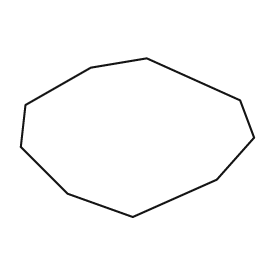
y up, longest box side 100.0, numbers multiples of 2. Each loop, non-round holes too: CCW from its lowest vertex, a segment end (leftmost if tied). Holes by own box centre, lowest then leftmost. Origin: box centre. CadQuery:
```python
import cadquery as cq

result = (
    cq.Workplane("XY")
    .moveTo(-2.0, -34.0)
    .lineTo(34.0, -18.0)
    .lineTo(50.0, 0.0)
    .lineTo(44.0, 16.0)
    .lineTo(4.0, 34.0)
    .lineTo(-20.0, 30.0)
    .lineTo(-48.0, 14.0)
    .lineTo(-50.0, -4.0)
    .lineTo(-30.0, -24.0)
    .close()
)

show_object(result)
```